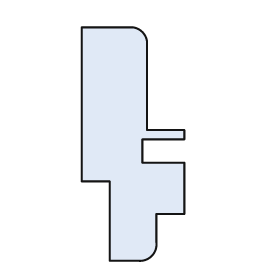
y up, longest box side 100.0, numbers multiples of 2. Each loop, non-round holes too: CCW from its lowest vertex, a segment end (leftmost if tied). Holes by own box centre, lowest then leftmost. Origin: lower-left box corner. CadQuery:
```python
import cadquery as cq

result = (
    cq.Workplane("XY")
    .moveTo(12.0, 0.0)
    .lineTo(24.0, 0.0)
    .threePointArc((30.0, 2.0), (32.0, 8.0))
    .lineTo(32.0, 20.0)
    .lineTo(44.0, 20.0)
    .lineTo(44.0, 42.0)
    .lineTo(26.0, 42.0)
    .lineTo(26.0, 52.0)
    .lineTo(44.0, 52.0)
    .lineTo(44.0, 56.0)
    .lineTo(28.0, 56.0)
    .lineTo(28.0, 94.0)
    .threePointArc((26.0, 98.0), (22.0, 100.0))
    .lineTo(0.0, 100.0)
    .lineTo(0.0, 34.0)
    .lineTo(12.0, 34.0)
    .close()
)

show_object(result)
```